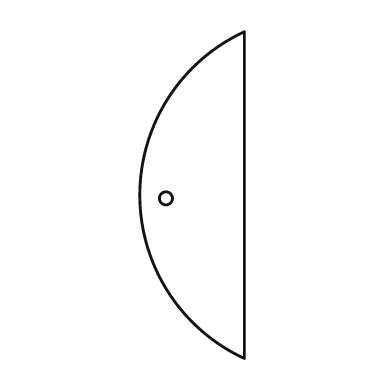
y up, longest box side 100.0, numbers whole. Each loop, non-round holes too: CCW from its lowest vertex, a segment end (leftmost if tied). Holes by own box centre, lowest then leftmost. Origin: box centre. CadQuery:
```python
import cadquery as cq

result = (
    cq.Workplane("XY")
    .moveTo(16.0, -50.0)
    .lineTo(16.0, 50.0)
    .threePointArc((-16.0, 0.0), (16.0, -50.0))
    .close()
    .moveTo(-8.0, -1.0)
    .circle(2.0)
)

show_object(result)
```